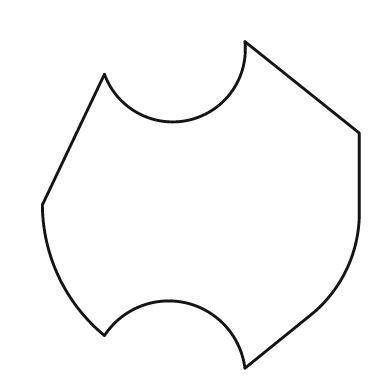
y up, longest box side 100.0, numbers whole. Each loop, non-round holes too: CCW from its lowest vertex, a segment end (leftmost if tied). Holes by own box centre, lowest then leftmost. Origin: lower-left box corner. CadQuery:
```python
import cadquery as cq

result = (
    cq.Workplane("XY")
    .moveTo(62.0, 0.0)
    .lineTo(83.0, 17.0)
    .threePointArc((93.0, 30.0), (97.0, 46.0))
    .lineTo(97.0, 72.0)
    .lineTo(62.0, 100.0)
    .threePointArc((45.0, 76.0), (19.0, 90.0))
    .lineTo(0.0, 50.0)
    .threePointArc((5.0, 28.0), (19.0, 10.0))
    .threePointArc((44.0, 20.0), (62.0, 0.0))
    .close()
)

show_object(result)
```